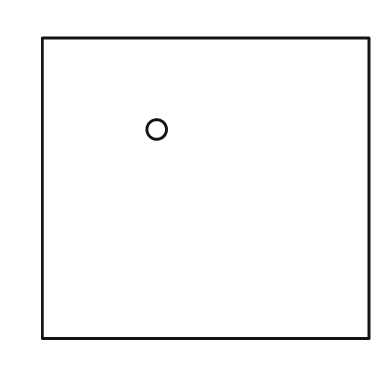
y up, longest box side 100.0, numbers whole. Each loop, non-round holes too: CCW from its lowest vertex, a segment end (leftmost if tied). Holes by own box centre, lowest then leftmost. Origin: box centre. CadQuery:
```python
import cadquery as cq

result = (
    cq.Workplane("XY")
    .moveTo(-50.0, -46.0)
    .lineTo(50.0, -46.0)
    .lineTo(50.0, 46.0)
    .lineTo(-50.0, 46.0)
    .close()
    .moveTo(-15.0, 18.0)
    .circle(3.0)
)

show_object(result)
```